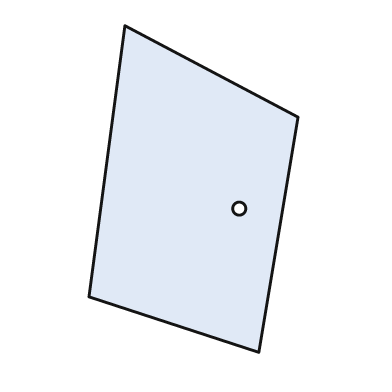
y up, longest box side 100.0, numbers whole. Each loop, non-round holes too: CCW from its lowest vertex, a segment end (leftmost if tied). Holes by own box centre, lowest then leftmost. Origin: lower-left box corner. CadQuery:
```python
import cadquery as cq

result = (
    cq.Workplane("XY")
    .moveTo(52.0, 0.0)
    .lineTo(64.0, 72.0)
    .lineTo(11.0, 100.0)
    .lineTo(0.0, 17.0)
    .close()
    .moveTo(46.0, 44.0)
    .circle(2.0)
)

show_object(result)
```